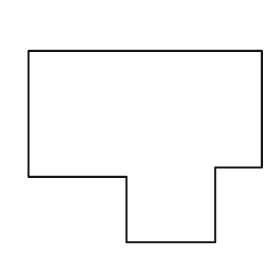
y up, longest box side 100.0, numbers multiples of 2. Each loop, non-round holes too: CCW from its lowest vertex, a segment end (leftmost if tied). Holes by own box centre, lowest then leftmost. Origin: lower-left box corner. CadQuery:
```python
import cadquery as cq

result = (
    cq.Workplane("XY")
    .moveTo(42.0, 0.0)
    .lineTo(80.0, 0.0)
    .lineTo(80.0, 32.0)
    .lineTo(100.0, 32.0)
    .lineTo(100.0, 82.0)
    .lineTo(0.0, 82.0)
    .lineTo(0.0, 28.0)
    .lineTo(42.0, 28.0)
    .close()
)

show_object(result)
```